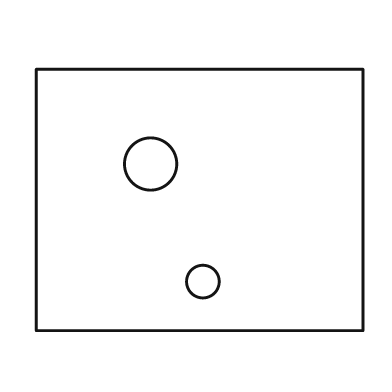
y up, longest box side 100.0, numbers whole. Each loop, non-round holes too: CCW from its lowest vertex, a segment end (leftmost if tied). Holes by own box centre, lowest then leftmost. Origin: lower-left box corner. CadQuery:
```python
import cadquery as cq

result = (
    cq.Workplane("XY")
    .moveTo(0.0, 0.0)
    .lineTo(100.0, 0.0)
    .lineTo(100.0, 80.0)
    .lineTo(0.0, 80.0)
    .close()
    .moveTo(51.0, 15.0)
    .circle(5.0)
    .moveTo(35.0, 51.0)
    .circle(8.0)
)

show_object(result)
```